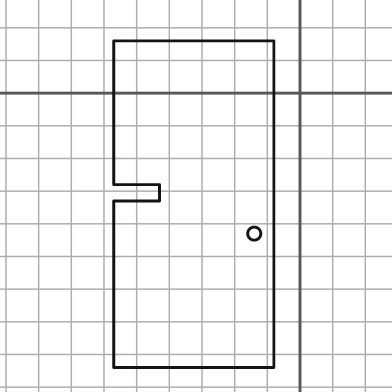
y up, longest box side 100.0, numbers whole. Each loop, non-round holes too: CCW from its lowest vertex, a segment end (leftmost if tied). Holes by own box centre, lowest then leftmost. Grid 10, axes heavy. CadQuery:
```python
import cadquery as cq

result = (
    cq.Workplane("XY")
    .moveTo(-57.0, -84.0)
    .lineTo(-8.0, -84.0)
    .lineTo(-8.0, 16.0)
    .lineTo(-57.0, 16.0)
    .lineTo(-57.0, -28.0)
    .lineTo(-43.0, -28.0)
    .lineTo(-43.0, -33.0)
    .lineTo(-57.0, -33.0)
    .close()
    .moveTo(-14.0, -43.0)
    .circle(2.0)
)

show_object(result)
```